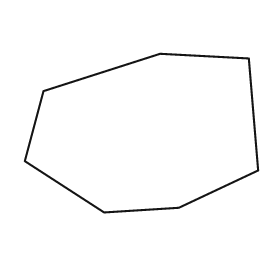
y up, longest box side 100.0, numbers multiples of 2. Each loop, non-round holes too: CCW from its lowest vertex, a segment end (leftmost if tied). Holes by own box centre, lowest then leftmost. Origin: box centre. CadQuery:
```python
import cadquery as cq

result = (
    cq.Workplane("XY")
    .moveTo(-16.0, -34.0)
    .lineTo(16.0, -32.0)
    .lineTo(50.0, -16.0)
    .lineTo(46.0, 32.0)
    .lineTo(8.0, 34.0)
    .lineTo(-42.0, 18.0)
    .lineTo(-50.0, -12.0)
    .close()
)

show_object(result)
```